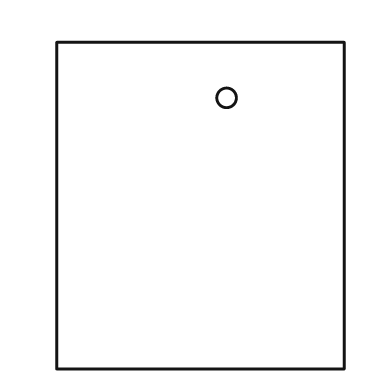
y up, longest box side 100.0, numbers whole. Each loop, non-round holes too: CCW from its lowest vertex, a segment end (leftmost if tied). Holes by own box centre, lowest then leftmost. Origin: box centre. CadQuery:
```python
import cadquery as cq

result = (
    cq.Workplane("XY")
    .moveTo(-44.0, -50.0)
    .lineTo(44.0, -50.0)
    .lineTo(44.0, 50.0)
    .lineTo(-44.0, 50.0)
    .close()
    .moveTo(8.0, 33.0)
    .circle(3.0)
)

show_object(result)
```